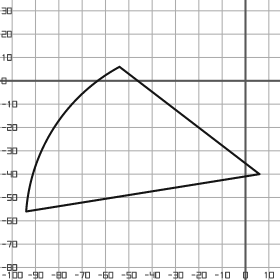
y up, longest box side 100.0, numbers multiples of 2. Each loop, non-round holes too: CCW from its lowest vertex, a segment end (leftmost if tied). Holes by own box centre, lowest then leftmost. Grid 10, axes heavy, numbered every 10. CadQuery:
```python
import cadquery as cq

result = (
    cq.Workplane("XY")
    .moveTo(-94.0, -56.0)
    .lineTo(6.0, -40.0)
    .lineTo(-54.0, 6.0)
    .threePointArc((-82.0, -20.0), (-94.0, -56.0))
    .close()
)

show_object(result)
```